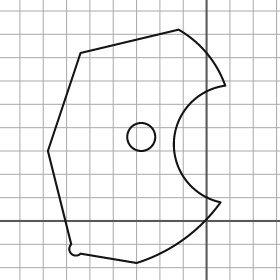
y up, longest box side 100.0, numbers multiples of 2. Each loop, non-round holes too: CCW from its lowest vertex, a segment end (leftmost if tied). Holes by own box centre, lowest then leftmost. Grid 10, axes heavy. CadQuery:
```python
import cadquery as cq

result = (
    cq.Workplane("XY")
    .moveTo(-30.0, -18.0)
    .threePointArc((-10.0, -8.0), (6.0, 8.0))
    .threePointArc((-14.0, 34.0), (8.0, 58.0))
    .threePointArc((0.0, 72.0), (-12.0, 82.0))
    .lineTo(-54.0, 72.0)
    .lineTo(-68.0, 30.0)
    .lineTo(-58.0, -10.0)
    .threePointArc((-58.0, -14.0), (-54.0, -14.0))
    .close()
    .moveTo(-28.0, 36.0)
    .circle(6.0)
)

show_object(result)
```